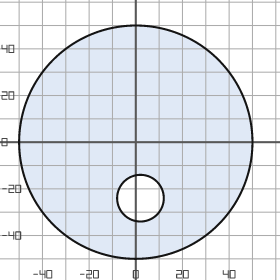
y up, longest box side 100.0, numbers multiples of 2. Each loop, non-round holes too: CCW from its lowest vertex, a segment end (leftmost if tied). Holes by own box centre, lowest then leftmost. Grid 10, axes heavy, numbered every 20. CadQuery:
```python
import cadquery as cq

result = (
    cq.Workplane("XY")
    .moveTo(0.0, 0.0)
    .circle(50.0)
    .moveTo(2.0, -24.0)
    .circle(10.0)
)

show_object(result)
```